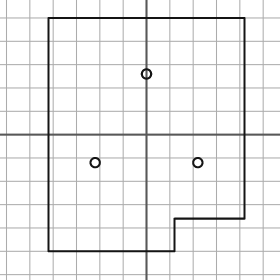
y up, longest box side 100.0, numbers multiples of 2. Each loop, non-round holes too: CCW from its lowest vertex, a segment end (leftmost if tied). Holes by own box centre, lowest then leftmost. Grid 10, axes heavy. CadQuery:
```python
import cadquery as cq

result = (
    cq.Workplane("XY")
    .moveTo(-42.0, -50.0)
    .lineTo(12.0, -50.0)
    .lineTo(12.0, -36.0)
    .lineTo(42.0, -36.0)
    .lineTo(42.0, 50.0)
    .lineTo(-42.0, 50.0)
    .close()
    .moveTo(-22.0, -12.0)
    .circle(2.0)
    .moveTo(22.0, -12.0)
    .circle(2.0)
    .moveTo(0.0, 26.0)
    .circle(2.0)
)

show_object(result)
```